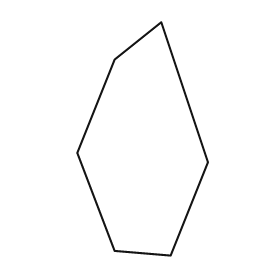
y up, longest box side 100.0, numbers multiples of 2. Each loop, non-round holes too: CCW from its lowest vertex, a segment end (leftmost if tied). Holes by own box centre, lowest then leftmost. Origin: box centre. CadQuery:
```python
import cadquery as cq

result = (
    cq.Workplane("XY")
    .moveTo(12.0, -50.0)
    .lineTo(28.0, -10.0)
    .lineTo(8.0, 50.0)
    .lineTo(-12.0, 34.0)
    .lineTo(-28.0, -6.0)
    .lineTo(-12.0, -48.0)
    .close()
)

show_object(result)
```